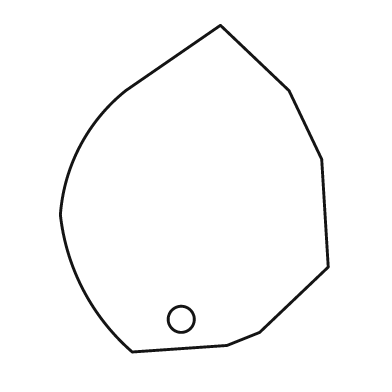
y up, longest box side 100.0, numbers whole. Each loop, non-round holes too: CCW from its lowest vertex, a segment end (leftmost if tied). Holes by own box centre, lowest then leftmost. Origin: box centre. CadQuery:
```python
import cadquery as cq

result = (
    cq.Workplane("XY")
    .moveTo(-19.0, -50.0)
    .lineTo(10.0, -48.0)
    .lineTo(20.0, -44.0)
    .lineTo(41.0, -24.0)
    .lineTo(39.0, 9.0)
    .lineTo(29.0, 30.0)
    .lineTo(8.0, 50.0)
    .lineTo(-21.0, 30.0)
    .threePointArc((-35.0, 13.0), (-41.0, -8.0))
    .threePointArc((-34.0, -31.0), (-19.0, -50.0))
    .close()
    .moveTo(-4.0, -40.0)
    .circle(4.0)
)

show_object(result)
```